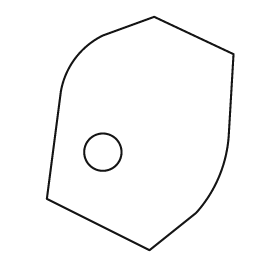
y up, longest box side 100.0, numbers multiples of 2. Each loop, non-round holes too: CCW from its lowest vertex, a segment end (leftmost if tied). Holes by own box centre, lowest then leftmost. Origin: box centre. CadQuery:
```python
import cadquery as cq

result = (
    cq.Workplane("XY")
    .moveTo(4.0, -50.0)
    .lineTo(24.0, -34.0)
    .threePointArc((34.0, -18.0), (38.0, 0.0))
    .lineTo(40.0, 34.0)
    .lineTo(6.0, 50.0)
    .lineTo(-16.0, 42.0)
    .threePointArc((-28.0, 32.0), (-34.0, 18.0))
    .lineTo(-40.0, -28.0)
    .close()
    .moveTo(-16.0, -8.0)
    .circle(8.0)
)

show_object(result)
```